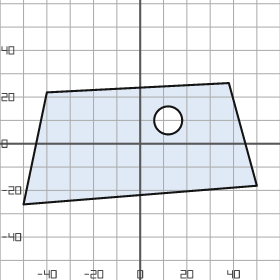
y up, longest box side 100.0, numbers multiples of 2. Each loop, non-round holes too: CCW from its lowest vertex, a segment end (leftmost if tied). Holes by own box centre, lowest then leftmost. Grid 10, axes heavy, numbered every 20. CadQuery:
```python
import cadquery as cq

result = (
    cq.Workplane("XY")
    .moveTo(-50.0, -26.0)
    .lineTo(50.0, -18.0)
    .lineTo(38.0, 26.0)
    .lineTo(-40.0, 22.0)
    .close()
    .moveTo(12.0, 10.0)
    .circle(6.0)
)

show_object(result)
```